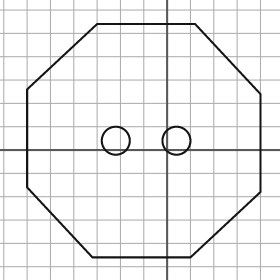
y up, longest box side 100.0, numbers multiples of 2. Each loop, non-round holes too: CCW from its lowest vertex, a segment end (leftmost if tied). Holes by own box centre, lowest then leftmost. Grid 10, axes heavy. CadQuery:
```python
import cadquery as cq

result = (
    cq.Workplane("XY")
    .moveTo(-32.0, -46.0)
    .lineTo(10.0, -46.0)
    .lineTo(40.0, -18.0)
    .lineTo(40.0, 24.0)
    .lineTo(12.0, 54.0)
    .lineTo(-30.0, 54.0)
    .lineTo(-60.0, 26.0)
    .lineTo(-60.0, -16.0)
    .close()
    .moveTo(-22.0, 4.0)
    .circle(6.0)
    .moveTo(4.0, 4.0)
    .circle(6.0)
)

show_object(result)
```